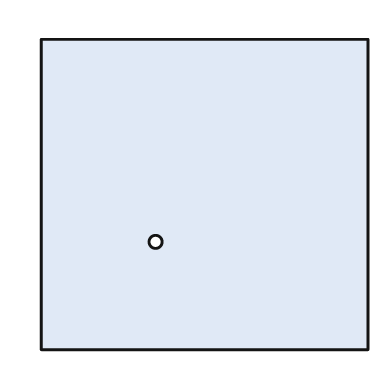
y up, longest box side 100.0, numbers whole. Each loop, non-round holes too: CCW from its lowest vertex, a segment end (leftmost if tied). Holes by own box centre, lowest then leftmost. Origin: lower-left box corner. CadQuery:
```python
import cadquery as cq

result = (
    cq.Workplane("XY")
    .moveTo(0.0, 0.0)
    .lineTo(100.0, 0.0)
    .lineTo(100.0, 95.0)
    .lineTo(0.0, 95.0)
    .close()
    .moveTo(35.0, 33.0)
    .circle(2.0)
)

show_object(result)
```